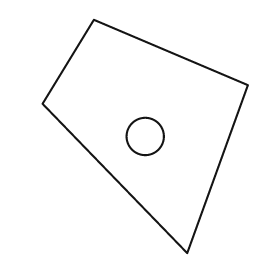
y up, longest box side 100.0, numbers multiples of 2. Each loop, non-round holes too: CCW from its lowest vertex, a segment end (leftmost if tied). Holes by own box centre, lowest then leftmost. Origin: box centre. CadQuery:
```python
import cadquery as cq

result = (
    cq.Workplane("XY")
    .moveTo(18.0, -50.0)
    .lineTo(44.0, 22.0)
    .lineTo(-22.0, 50.0)
    .lineTo(-44.0, 14.0)
    .close()
    .moveTo(0.0, 0.0)
    .circle(8.0)
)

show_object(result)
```